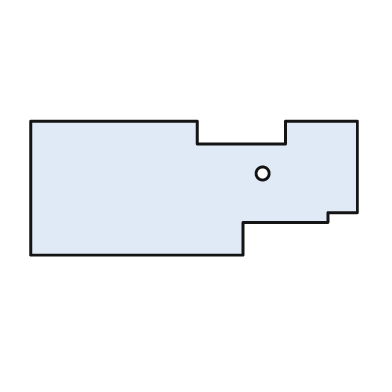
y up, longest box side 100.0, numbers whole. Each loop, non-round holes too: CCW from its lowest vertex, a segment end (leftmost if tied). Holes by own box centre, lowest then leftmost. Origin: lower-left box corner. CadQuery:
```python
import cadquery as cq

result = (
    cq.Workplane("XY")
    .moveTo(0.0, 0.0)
    .lineTo(65.0, 0.0)
    .lineTo(65.0, 10.0)
    .lineTo(91.0, 10.0)
    .lineTo(91.0, 13.0)
    .lineTo(100.0, 13.0)
    .lineTo(100.0, 41.0)
    .lineTo(78.0, 41.0)
    .lineTo(78.0, 34.0)
    .lineTo(51.0, 34.0)
    .lineTo(51.0, 41.0)
    .lineTo(0.0, 41.0)
    .close()
    .moveTo(71.0, 25.0)
    .circle(2.0)
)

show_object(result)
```